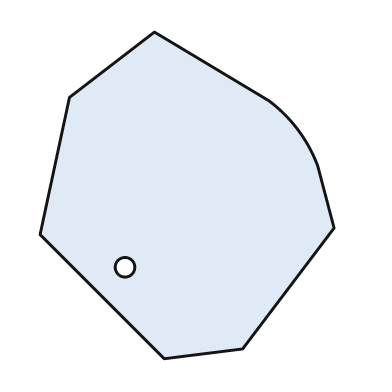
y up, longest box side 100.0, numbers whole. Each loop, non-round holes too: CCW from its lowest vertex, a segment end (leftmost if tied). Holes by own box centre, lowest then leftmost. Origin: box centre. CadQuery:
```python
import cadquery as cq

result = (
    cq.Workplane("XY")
    .moveTo(-7.0, -50.0)
    .lineTo(17.0, -47.0)
    .lineTo(45.0, -10.0)
    .lineTo(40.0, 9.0)
    .threePointArc((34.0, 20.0), (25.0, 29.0))
    .lineTo(-10.0, 50.0)
    .lineTo(-36.0, 30.0)
    .lineTo(-45.0, -12.0)
    .close()
    .moveTo(-19.0, -22.0)
    .circle(3.0)
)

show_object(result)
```